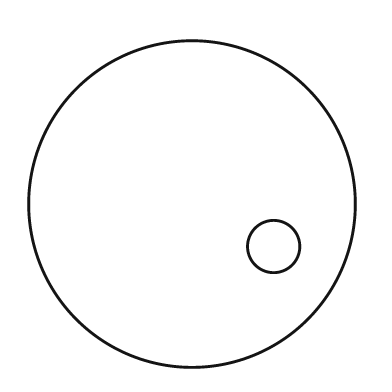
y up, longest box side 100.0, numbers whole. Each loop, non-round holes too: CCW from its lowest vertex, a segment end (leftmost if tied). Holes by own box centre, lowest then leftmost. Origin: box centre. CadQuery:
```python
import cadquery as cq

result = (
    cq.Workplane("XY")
    .moveTo(0.0, 0.0)
    .circle(50.0)
    .moveTo(25.0, -13.0)
    .circle(8.0)
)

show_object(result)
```